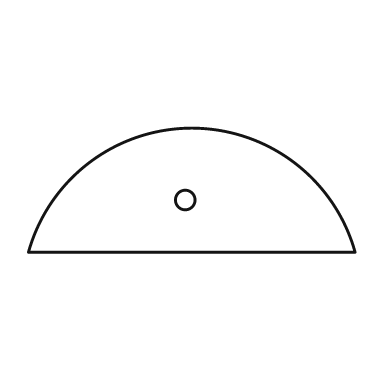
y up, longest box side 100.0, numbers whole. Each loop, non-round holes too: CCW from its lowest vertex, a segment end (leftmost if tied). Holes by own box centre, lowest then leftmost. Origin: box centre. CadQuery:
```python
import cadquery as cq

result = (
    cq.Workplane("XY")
    .moveTo(-50.0, -19.0)
    .lineTo(50.0, -19.0)
    .threePointArc((0.0, 19.0), (-50.0, -19.0))
    .close()
    .moveTo(-2.0, -3.0)
    .circle(3.0)
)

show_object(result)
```